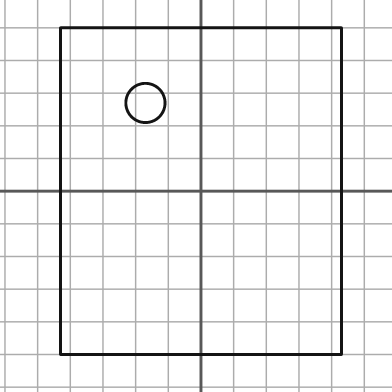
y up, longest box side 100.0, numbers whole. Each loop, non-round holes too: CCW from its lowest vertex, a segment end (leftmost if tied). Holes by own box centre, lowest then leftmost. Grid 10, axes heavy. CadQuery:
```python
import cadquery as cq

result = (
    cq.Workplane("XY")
    .moveTo(-43.0, -50.0)
    .lineTo(43.0, -50.0)
    .lineTo(43.0, 50.0)
    .lineTo(-43.0, 50.0)
    .close()
    .moveTo(-17.0, 27.0)
    .circle(6.0)
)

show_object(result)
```